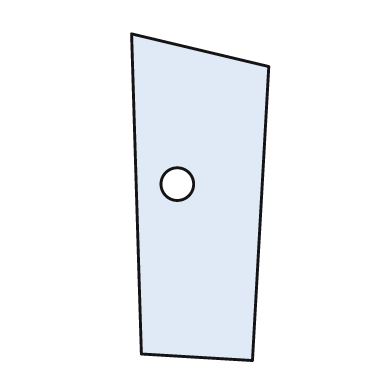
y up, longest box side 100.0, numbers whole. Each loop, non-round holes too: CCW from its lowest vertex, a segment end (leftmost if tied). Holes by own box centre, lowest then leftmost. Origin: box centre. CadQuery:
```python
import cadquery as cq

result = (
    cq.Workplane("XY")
    .moveTo(16.0, -50.0)
    .lineTo(21.0, 40.0)
    .lineTo(-21.0, 50.0)
    .lineTo(-18.0, -48.0)
    .close()
    .moveTo(-7.0, 4.0)
    .circle(5.0)
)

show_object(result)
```